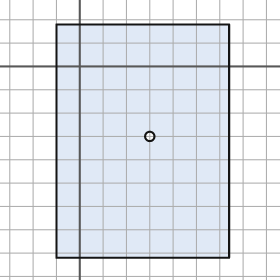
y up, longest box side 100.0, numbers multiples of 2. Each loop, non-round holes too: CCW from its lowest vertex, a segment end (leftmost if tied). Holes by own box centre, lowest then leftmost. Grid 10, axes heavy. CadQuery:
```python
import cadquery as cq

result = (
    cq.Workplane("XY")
    .moveTo(-10.0, -82.0)
    .lineTo(64.0, -82.0)
    .lineTo(64.0, 18.0)
    .lineTo(-10.0, 18.0)
    .close()
    .moveTo(30.0, -30.0)
    .circle(2.0)
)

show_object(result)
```